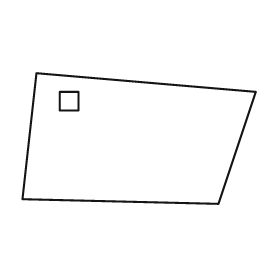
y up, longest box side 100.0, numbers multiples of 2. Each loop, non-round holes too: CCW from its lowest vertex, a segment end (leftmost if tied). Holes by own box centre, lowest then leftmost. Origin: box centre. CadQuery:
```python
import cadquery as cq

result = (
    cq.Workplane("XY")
    .moveTo(34.0, -28.0)
    .lineTo(50.0, 20.0)
    .lineTo(-44.0, 28.0)
    .lineTo(-50.0, -26.0)
    .close()
    .moveTo(-34.0, 12.0)
    .lineTo(-26.0, 12.0)
    .lineTo(-26.0, 20.0)
    .lineTo(-34.0, 20.0)
    .close()
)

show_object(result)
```